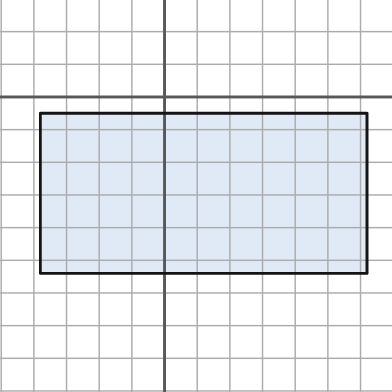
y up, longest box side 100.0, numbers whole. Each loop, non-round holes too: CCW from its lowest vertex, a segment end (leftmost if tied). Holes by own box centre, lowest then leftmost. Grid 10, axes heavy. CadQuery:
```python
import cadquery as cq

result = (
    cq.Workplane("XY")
    .moveTo(-38.0, -54.0)
    .lineTo(62.0, -54.0)
    .lineTo(62.0, -5.0)
    .lineTo(-38.0, -5.0)
    .close()
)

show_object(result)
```